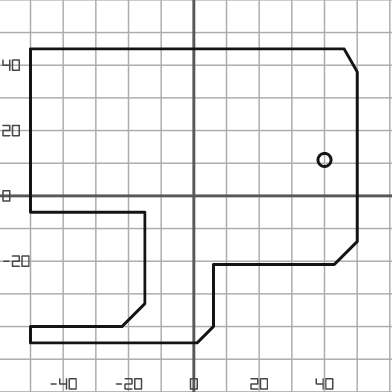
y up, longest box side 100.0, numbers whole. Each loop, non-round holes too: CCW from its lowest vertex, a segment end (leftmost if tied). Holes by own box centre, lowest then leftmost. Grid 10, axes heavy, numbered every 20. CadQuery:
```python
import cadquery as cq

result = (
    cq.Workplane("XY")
    .moveTo(-50.0, -45.0)
    .lineTo(1.0, -45.0)
    .lineTo(6.0, -40.0)
    .lineTo(6.0, -21.0)
    .lineTo(43.0, -21.0)
    .lineTo(50.0, -14.0)
    .lineTo(50.0, 38.0)
    .lineTo(46.0, 45.0)
    .lineTo(-50.0, 45.0)
    .lineTo(-50.0, -5.0)
    .lineTo(-15.0, -5.0)
    .lineTo(-15.0, -33.0)
    .lineTo(-22.0, -40.0)
    .lineTo(-50.0, -40.0)
    .close()
    .moveTo(40.0, 11.0)
    .circle(2.0)
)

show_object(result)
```